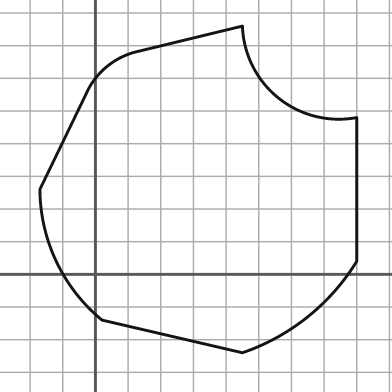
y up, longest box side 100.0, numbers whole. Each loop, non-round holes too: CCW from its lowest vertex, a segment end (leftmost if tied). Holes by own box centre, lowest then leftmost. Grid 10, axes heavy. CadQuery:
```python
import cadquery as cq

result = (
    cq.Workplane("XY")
    .moveTo(45.0, -24.0)
    .threePointArc((65.0, -13.0), (80.0, 4.0))
    .lineTo(80.0, 48.0)
    .threePointArc((56.0, 54.0), (45.0, 76.0))
    .lineTo(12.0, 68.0)
    .threePointArc((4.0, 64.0), (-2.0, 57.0))
    .lineTo(-17.0, 26.0)
    .threePointArc((-12.0, 4.0), (2.0, -14.0))
    .close()
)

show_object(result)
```